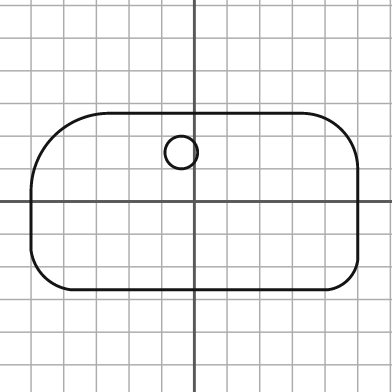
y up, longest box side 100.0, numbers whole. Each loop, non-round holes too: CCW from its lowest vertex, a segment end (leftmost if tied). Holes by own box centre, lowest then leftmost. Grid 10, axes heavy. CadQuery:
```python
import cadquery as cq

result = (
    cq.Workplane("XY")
    .moveTo(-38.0, -27.0)
    .lineTo(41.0, -27.0)
    .threePointArc((47.0, -24.0), (50.0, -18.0))
    .lineTo(50.0, 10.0)
    .threePointArc((45.0, 22.0), (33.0, 27.0))
    .lineTo(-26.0, 27.0)
    .threePointArc((-43.0, 20.0), (-50.0, 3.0))
    .lineTo(-50.0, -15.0)
    .threePointArc((-46.0, -23.0), (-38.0, -27.0))
    .close()
    .moveTo(-4.0, 15.0)
    .circle(5.0)
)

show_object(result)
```